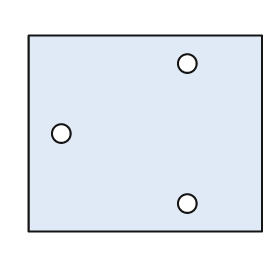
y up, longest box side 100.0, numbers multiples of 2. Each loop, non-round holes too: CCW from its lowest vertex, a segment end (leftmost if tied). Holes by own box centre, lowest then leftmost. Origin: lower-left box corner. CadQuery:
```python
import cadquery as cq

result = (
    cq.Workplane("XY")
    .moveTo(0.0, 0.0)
    .lineTo(100.0, 0.0)
    .lineTo(100.0, 84.0)
    .lineTo(0.0, 84.0)
    .close()
    .moveTo(68.0, 12.0)
    .circle(4.0)
    .moveTo(14.0, 42.0)
    .circle(4.0)
    .moveTo(68.0, 72.0)
    .circle(4.0)
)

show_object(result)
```